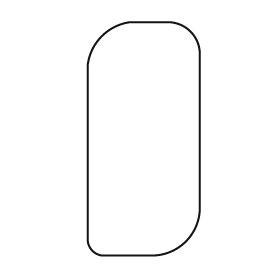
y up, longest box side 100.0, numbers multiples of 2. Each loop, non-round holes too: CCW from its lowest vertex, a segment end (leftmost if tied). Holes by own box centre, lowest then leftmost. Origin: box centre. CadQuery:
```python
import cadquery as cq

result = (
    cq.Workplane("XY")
    .moveTo(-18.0, -50.0)
    .lineTo(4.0, -50.0)
    .threePointArc((18.0, -44.0), (24.0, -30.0))
    .lineTo(24.0, 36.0)
    .threePointArc((20.0, 46.0), (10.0, 50.0))
    .lineTo(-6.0, 50.0)
    .threePointArc((-18.0, 44.0), (-24.0, 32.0))
    .lineTo(-24.0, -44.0)
    .threePointArc((-22.0, -48.0), (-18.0, -50.0))
    .close()
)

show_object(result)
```